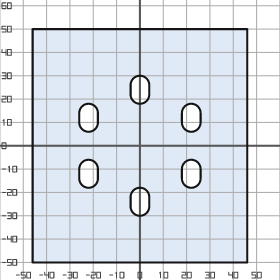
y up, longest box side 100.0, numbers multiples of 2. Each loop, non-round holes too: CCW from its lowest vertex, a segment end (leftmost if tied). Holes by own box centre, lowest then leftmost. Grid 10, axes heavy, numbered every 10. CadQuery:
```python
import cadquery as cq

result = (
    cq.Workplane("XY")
    .moveTo(-46.0, -50.0)
    .lineTo(46.0, -50.0)
    .lineTo(46.0, 50.0)
    .lineTo(-46.0, 50.0)
    .close()
    .moveTo(-4.0, -26.0)
    .threePointArc((0.0, -30.0), (4.0, -26.0))
    .lineTo(4.0, -22.0)
    .threePointArc((0.0, -18.0), (-4.0, -22.0))
    .close()
    .moveTo(-26.0, -14.0)
    .threePointArc((-22.0, -18.0), (-18.0, -14.0))
    .lineTo(-18.0, -10.0)
    .threePointArc((-22.0, -6.0), (-26.0, -10.0))
    .close()
    .moveTo(18.0, -14.0)
    .threePointArc((22.0, -18.0), (26.0, -14.0))
    .lineTo(26.0, -10.0)
    .threePointArc((22.0, -6.0), (18.0, -10.0))
    .close()
    .moveTo(-26.0, 10.0)
    .threePointArc((-22.0, 6.0), (-18.0, 10.0))
    .lineTo(-18.0, 14.0)
    .threePointArc((-22.0, 18.0), (-26.0, 14.0))
    .close()
    .moveTo(18.0, 10.0)
    .threePointArc((22.0, 6.0), (26.0, 10.0))
    .lineTo(26.0, 14.0)
    .threePointArc((22.0, 18.0), (18.0, 14.0))
    .close()
    .moveTo(-4.0, 22.0)
    .threePointArc((0.0, 18.0), (4.0, 22.0))
    .lineTo(4.0, 26.0)
    .threePointArc((0.0, 30.0), (-4.0, 26.0))
    .close()
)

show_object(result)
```